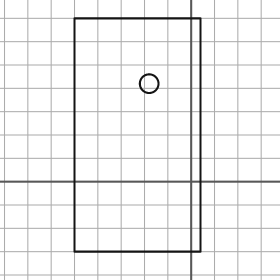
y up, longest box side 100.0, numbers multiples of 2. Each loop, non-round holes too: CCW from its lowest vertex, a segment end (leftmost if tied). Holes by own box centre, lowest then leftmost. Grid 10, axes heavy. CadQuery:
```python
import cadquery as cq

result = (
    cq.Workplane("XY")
    .moveTo(-50.0, -30.0)
    .lineTo(4.0, -30.0)
    .lineTo(4.0, 70.0)
    .lineTo(-50.0, 70.0)
    .close()
    .moveTo(-18.0, 42.0)
    .circle(4.0)
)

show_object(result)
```